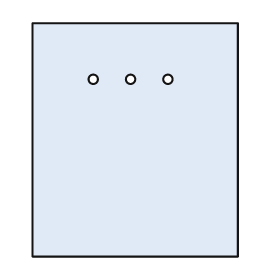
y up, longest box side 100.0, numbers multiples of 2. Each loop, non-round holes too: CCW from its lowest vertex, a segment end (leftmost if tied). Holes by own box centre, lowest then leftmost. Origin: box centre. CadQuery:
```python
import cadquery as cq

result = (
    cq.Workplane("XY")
    .moveTo(-44.0, -50.0)
    .lineTo(44.0, -50.0)
    .lineTo(44.0, 50.0)
    .lineTo(-44.0, 50.0)
    .close()
    .moveTo(-18.0, 26.0)
    .circle(2.0)
    .moveTo(-2.0, 26.0)
    .circle(2.0)
    .moveTo(14.0, 26.0)
    .circle(2.0)
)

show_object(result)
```